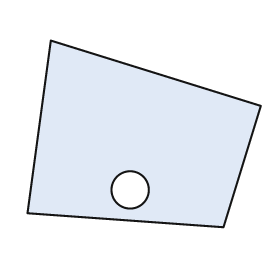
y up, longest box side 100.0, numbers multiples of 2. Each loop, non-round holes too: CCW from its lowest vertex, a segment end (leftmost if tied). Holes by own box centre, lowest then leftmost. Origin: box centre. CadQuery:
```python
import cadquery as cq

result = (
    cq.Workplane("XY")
    .moveTo(34.0, -40.0)
    .lineTo(50.0, 12.0)
    .lineTo(-40.0, 40.0)
    .lineTo(-50.0, -34.0)
    .close()
    .moveTo(-6.0, -24.0)
    .circle(8.0)
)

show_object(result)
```